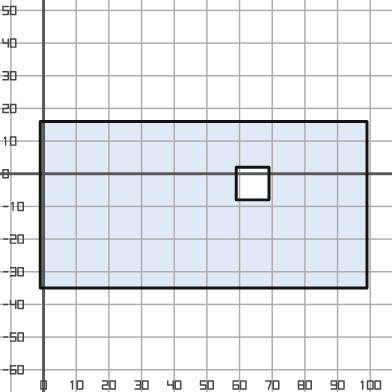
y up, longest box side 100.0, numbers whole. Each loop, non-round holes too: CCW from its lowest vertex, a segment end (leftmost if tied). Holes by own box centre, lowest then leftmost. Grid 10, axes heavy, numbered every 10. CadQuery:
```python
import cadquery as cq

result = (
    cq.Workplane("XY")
    .moveTo(-1.0, -35.0)
    .lineTo(99.0, -35.0)
    .lineTo(99.0, 16.0)
    .lineTo(-1.0, 16.0)
    .close()
    .moveTo(59.0, -8.0)
    .lineTo(69.0, -8.0)
    .lineTo(69.0, 2.0)
    .lineTo(59.0, 2.0)
    .close()
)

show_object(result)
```